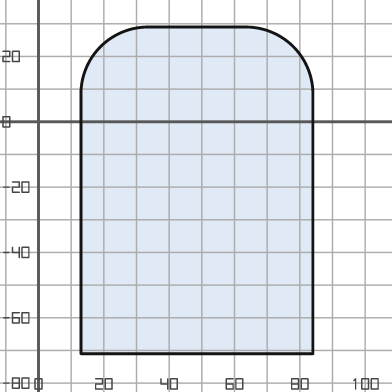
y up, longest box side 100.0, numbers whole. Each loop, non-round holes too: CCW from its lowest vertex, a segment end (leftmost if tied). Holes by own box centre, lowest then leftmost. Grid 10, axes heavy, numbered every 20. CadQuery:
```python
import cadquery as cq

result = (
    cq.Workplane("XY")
    .moveTo(13.0, -71.0)
    .lineTo(84.0, -71.0)
    .lineTo(84.0, 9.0)
    .threePointArc((78.0, 23.0), (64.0, 29.0))
    .lineTo(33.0, 29.0)
    .threePointArc((19.0, 23.0), (13.0, 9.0))
    .close()
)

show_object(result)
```